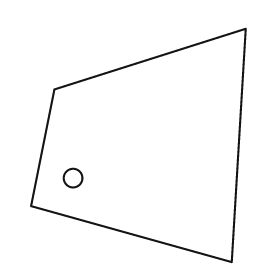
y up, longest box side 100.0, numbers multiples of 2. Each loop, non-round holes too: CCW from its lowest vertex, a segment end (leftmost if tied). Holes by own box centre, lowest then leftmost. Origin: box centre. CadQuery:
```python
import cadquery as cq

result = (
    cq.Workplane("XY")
    .moveTo(40.0, -50.0)
    .lineTo(46.0, 50.0)
    .lineTo(-36.0, 24.0)
    .lineTo(-46.0, -26.0)
    .close()
    .moveTo(-28.0, -14.0)
    .circle(4.0)
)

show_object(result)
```